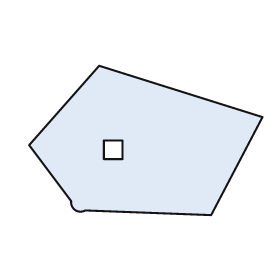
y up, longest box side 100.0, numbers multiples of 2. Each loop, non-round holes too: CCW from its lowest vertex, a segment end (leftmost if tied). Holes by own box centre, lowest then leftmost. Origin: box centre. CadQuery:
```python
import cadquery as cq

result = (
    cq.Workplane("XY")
    .moveTo(28.0, -32.0)
    .lineTo(50.0, 10.0)
    .lineTo(-20.0, 32.0)
    .lineTo(-50.0, -2.0)
    .lineTo(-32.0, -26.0)
    .threePointArc((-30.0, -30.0), (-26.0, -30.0))
    .close()
    .moveTo(-18.0, -8.0)
    .lineTo(-10.0, -8.0)
    .lineTo(-10.0, 0.0)
    .lineTo(-18.0, 0.0)
    .close()
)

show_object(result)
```